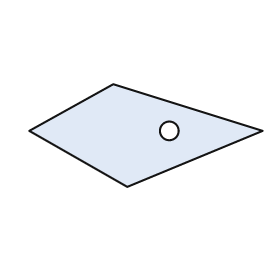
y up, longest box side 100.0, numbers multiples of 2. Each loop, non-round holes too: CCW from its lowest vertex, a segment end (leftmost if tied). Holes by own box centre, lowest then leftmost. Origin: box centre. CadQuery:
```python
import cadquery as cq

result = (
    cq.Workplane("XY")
    .moveTo(-8.0, -22.0)
    .lineTo(50.0, 2.0)
    .lineTo(-14.0, 22.0)
    .lineTo(-50.0, 2.0)
    .close()
    .moveTo(10.0, 2.0)
    .circle(4.0)
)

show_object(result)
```